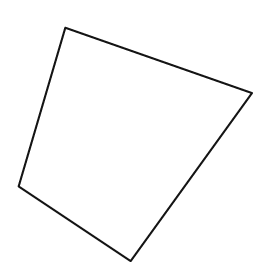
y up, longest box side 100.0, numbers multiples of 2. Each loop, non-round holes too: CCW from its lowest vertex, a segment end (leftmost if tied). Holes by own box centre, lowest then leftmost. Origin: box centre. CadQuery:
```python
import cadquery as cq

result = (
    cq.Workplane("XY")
    .moveTo(-2.0, -50.0)
    .lineTo(50.0, 22.0)
    .lineTo(-30.0, 50.0)
    .lineTo(-50.0, -18.0)
    .close()
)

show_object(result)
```